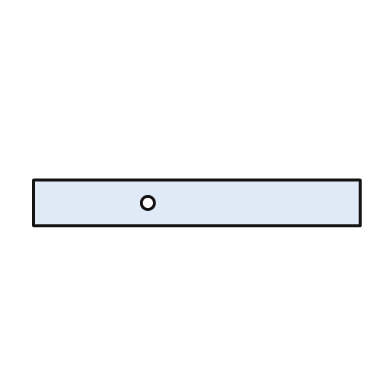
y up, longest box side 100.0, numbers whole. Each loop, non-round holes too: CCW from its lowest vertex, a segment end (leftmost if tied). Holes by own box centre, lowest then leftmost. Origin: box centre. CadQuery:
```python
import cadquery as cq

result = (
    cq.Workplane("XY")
    .moveTo(-50.0, -7.0)
    .lineTo(50.0, -7.0)
    .lineTo(50.0, 7.0)
    .lineTo(-50.0, 7.0)
    .close()
    .moveTo(-15.0, 0.0)
    .circle(2.0)
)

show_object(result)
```